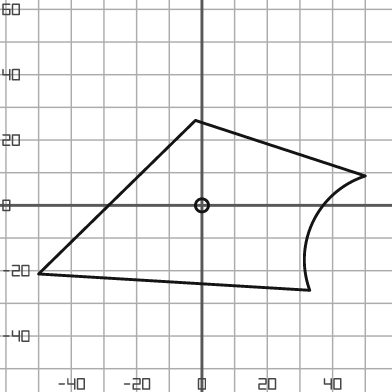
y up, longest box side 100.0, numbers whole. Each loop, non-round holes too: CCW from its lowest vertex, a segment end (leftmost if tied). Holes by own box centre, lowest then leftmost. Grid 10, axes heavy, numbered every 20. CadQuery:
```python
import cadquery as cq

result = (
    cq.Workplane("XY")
    .moveTo(33.0, -26.0)
    .threePointArc((34.0, -5.0), (50.0, 9.0))
    .lineTo(-2.0, 26.0)
    .lineTo(-50.0, -21.0)
    .close()
    .moveTo(0.0, 0.0)
    .circle(2.0)
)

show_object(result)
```